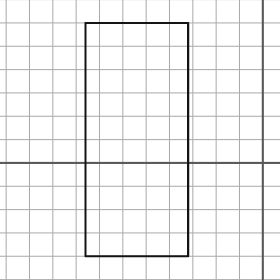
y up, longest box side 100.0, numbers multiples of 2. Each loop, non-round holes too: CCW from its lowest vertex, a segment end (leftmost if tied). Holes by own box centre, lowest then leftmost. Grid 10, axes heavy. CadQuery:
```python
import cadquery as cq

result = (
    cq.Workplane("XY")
    .moveTo(-76.0, -40.0)
    .lineTo(-32.0, -40.0)
    .lineTo(-32.0, 60.0)
    .lineTo(-76.0, 60.0)
    .close()
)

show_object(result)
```